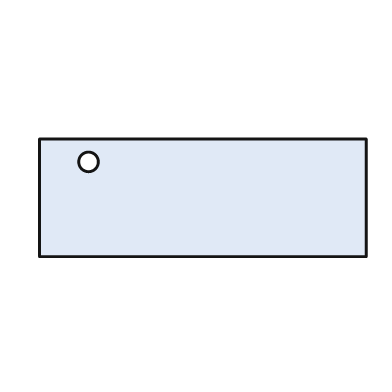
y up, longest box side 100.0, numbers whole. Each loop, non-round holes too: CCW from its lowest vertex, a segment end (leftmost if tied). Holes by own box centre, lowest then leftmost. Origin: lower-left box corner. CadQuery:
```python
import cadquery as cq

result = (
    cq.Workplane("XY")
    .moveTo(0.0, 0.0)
    .lineTo(100.0, 0.0)
    .lineTo(100.0, 36.0)
    .lineTo(0.0, 36.0)
    .close()
    .moveTo(15.0, 29.0)
    .circle(3.0)
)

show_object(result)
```